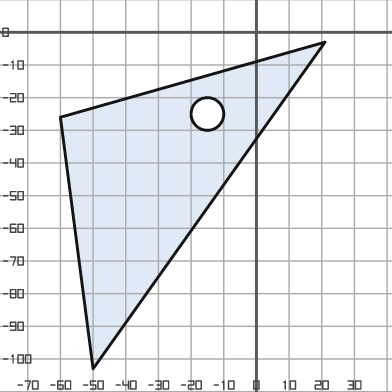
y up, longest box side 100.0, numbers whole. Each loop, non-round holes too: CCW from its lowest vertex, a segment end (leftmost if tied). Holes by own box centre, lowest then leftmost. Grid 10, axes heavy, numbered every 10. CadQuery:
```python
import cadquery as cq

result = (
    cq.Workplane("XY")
    .moveTo(-50.0, -103.0)
    .lineTo(21.0, -3.0)
    .lineTo(-60.0, -26.0)
    .close()
    .moveTo(-15.0, -25.0)
    .circle(5.0)
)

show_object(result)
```